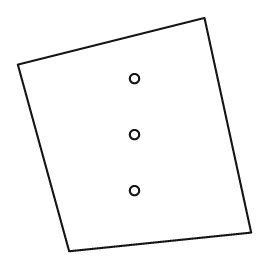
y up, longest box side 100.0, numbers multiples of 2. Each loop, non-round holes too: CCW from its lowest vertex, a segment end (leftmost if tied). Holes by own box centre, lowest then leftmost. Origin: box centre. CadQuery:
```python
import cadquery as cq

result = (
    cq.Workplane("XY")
    .moveTo(-28.0, -50.0)
    .lineTo(50.0, -42.0)
    .lineTo(30.0, 50.0)
    .lineTo(-50.0, 30.0)
    .close()
    .moveTo(0.0, -24.0)
    .circle(2.0)
    .moveTo(0.0, 0.0)
    .circle(2.0)
    .moveTo(0.0, 24.0)
    .circle(2.0)
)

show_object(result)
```